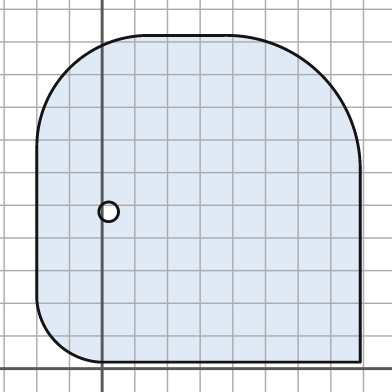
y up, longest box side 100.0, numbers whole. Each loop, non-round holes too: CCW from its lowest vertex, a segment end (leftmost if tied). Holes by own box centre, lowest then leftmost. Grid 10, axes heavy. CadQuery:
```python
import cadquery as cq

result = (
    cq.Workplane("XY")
    .moveTo(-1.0, 2.0)
    .lineTo(79.0, 2.0)
    .lineTo(79.0, 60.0)
    .threePointArc((67.0, 90.0), (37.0, 102.0))
    .lineTo(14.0, 102.0)
    .threePointArc((-10.0, 92.0), (-20.0, 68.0))
    .lineTo(-20.0, 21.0)
    .threePointArc((-14.0, 8.0), (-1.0, 2.0))
    .close()
    .moveTo(2.0, 48.0)
    .circle(3.0)
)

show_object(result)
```